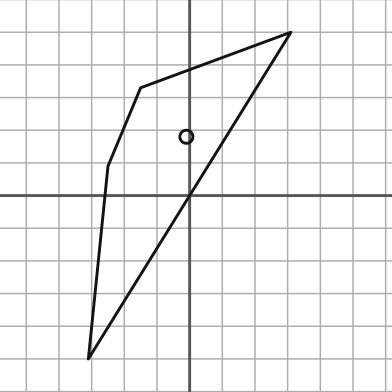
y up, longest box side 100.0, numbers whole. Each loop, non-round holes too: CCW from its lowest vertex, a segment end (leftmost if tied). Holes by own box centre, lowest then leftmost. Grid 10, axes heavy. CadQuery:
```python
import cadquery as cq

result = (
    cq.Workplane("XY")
    .moveTo(-31.0, -50.0)
    .lineTo(31.0, 50.0)
    .lineTo(-15.0, 33.0)
    .lineTo(-25.0, 9.0)
    .close()
    .moveTo(-1.0, 18.0)
    .circle(2.0)
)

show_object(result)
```